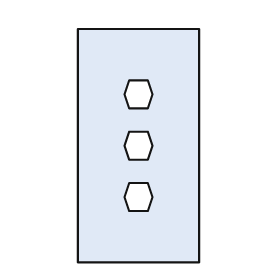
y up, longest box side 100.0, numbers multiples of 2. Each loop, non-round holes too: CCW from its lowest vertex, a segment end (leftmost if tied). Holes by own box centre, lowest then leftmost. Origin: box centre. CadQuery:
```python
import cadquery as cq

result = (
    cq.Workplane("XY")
    .moveTo(-26.0, -50.0)
    .lineTo(26.0, -50.0)
    .lineTo(26.0, 50.0)
    .lineTo(-26.0, 50.0)
    .close()
    .moveTo(-4.0, -28.0)
    .lineTo(4.0, -28.0)
    .lineTo(6.0, -22.0)
    .lineTo(4.0, -16.0)
    .lineTo(-4.0, -16.0)
    .lineTo(-6.0, -22.0)
    .close()
    .moveTo(-4.0, -6.0)
    .lineTo(4.0, -6.0)
    .lineTo(6.0, 0.0)
    .lineTo(4.0, 6.0)
    .lineTo(-4.0, 6.0)
    .lineTo(-6.0, 0.0)
    .close()
    .moveTo(-4.0, 16.0)
    .lineTo(4.0, 16.0)
    .lineTo(6.0, 22.0)
    .lineTo(4.0, 28.0)
    .lineTo(-4.0, 28.0)
    .lineTo(-6.0, 22.0)
    .close()
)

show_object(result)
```